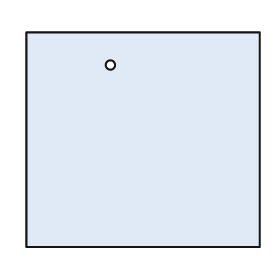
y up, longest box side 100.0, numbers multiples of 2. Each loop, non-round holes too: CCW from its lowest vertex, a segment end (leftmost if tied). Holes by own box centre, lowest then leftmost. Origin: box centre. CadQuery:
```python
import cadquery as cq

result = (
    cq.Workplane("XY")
    .moveTo(-50.0, -46.0)
    .lineTo(50.0, -46.0)
    .lineTo(50.0, 46.0)
    .lineTo(-50.0, 46.0)
    .close()
    .moveTo(-14.0, 32.0)
    .circle(2.0)
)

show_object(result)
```